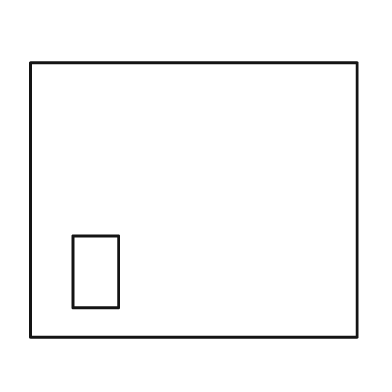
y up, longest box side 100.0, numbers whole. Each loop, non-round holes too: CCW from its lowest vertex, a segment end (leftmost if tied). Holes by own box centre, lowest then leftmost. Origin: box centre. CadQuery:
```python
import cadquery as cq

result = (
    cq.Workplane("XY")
    .moveTo(-50.0, -42.0)
    .lineTo(50.0, -42.0)
    .lineTo(50.0, 42.0)
    .lineTo(-50.0, 42.0)
    .close()
    .moveTo(-37.0, -33.0)
    .lineTo(-23.0, -33.0)
    .lineTo(-23.0, -11.0)
    .lineTo(-37.0, -11.0)
    .close()
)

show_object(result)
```